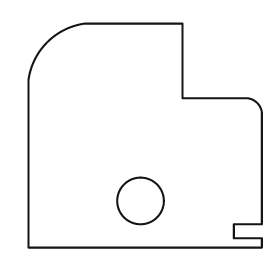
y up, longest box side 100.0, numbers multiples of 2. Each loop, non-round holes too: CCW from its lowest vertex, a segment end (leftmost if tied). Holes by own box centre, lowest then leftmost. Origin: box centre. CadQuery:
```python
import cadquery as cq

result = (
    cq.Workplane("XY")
    .moveTo(-50.0, -48.0)
    .lineTo(50.0, -48.0)
    .lineTo(50.0, -44.0)
    .lineTo(38.0, -44.0)
    .lineTo(38.0, -38.0)
    .lineTo(50.0, -38.0)
    .lineTo(50.0, 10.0)
    .threePointArc((48.0, 14.0), (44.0, 16.0))
    .lineTo(16.0, 16.0)
    .lineTo(16.0, 48.0)
    .lineTo(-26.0, 48.0)
    .threePointArc((-42.0, 40.0), (-50.0, 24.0))
    .close()
    .moveTo(-2.0, -28.0)
    .circle(10.0)
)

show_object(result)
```